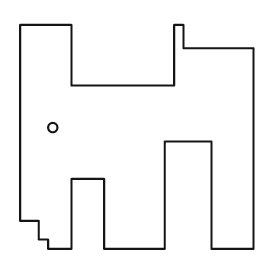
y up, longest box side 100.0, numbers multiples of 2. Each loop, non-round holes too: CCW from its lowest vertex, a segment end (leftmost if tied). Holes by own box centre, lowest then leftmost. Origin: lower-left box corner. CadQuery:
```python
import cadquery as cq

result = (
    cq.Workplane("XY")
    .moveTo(12.0, 0.0)
    .lineTo(22.0, 0.0)
    .lineTo(22.0, 30.0)
    .lineTo(36.0, 30.0)
    .lineTo(36.0, 0.0)
    .lineTo(62.0, 0.0)
    .lineTo(62.0, 46.0)
    .lineTo(82.0, 46.0)
    .lineTo(82.0, 0.0)
    .lineTo(100.0, 0.0)
    .lineTo(100.0, 86.0)
    .lineTo(70.0, 86.0)
    .lineTo(70.0, 96.0)
    .lineTo(66.0, 96.0)
    .lineTo(66.0, 70.0)
    .lineTo(22.0, 70.0)
    .lineTo(22.0, 96.0)
    .lineTo(0.0, 96.0)
    .lineTo(0.0, 12.0)
    .lineTo(8.0, 12.0)
    .lineTo(8.0, 4.0)
    .lineTo(12.0, 4.0)
    .close()
    .moveTo(14.0, 52.0)
    .circle(2.0)
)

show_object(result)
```